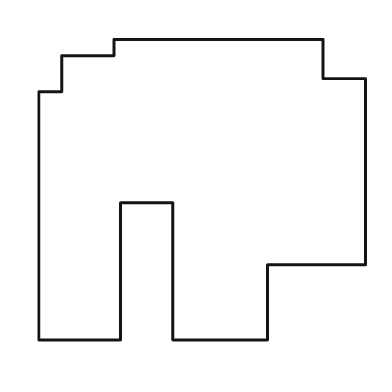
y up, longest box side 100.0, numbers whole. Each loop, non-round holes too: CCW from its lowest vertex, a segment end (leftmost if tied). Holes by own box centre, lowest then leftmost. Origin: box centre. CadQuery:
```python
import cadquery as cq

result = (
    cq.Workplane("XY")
    .moveTo(-50.0, -46.0)
    .lineTo(-25.0, -46.0)
    .lineTo(-25.0, -4.0)
    .lineTo(-9.0, -4.0)
    .lineTo(-9.0, -46.0)
    .lineTo(20.0, -46.0)
    .lineTo(20.0, -23.0)
    .lineTo(50.0, -23.0)
    .lineTo(50.0, 34.0)
    .lineTo(37.0, 34.0)
    .lineTo(37.0, 46.0)
    .lineTo(-27.0, 46.0)
    .lineTo(-27.0, 41.0)
    .lineTo(-43.0, 41.0)
    .lineTo(-43.0, 30.0)
    .lineTo(-50.0, 30.0)
    .close()
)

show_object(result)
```